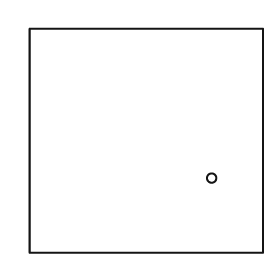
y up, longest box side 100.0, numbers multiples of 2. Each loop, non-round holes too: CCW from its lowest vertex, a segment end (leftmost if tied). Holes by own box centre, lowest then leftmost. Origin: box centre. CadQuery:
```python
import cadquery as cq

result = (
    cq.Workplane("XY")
    .moveTo(-50.0, -48.0)
    .lineTo(50.0, -48.0)
    .lineTo(50.0, 48.0)
    .lineTo(-50.0, 48.0)
    .close()
    .moveTo(28.0, -16.0)
    .circle(2.0)
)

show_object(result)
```